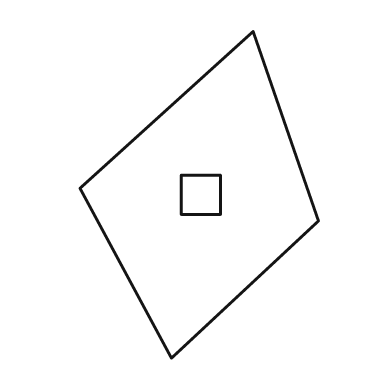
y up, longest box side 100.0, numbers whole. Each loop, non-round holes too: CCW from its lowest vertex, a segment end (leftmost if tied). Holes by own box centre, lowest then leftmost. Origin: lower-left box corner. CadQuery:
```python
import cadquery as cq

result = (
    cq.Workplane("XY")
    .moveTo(28.0, 0.0)
    .lineTo(73.0, 42.0)
    .lineTo(53.0, 100.0)
    .lineTo(0.0, 52.0)
    .close()
    .moveTo(31.0, 44.0)
    .lineTo(43.0, 44.0)
    .lineTo(43.0, 56.0)
    .lineTo(31.0, 56.0)
    .close()
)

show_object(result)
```